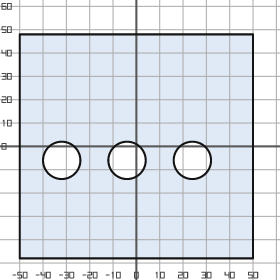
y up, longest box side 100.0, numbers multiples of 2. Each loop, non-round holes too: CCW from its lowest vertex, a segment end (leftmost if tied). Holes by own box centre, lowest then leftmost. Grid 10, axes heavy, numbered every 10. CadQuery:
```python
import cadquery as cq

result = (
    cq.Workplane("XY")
    .moveTo(-50.0, -48.0)
    .lineTo(50.0, -48.0)
    .lineTo(50.0, 48.0)
    .lineTo(-50.0, 48.0)
    .close()
    .moveTo(-32.0, -6.0)
    .circle(8.0)
    .moveTo(-4.0, -6.0)
    .circle(8.0)
    .moveTo(24.0, -6.0)
    .circle(8.0)
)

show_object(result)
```